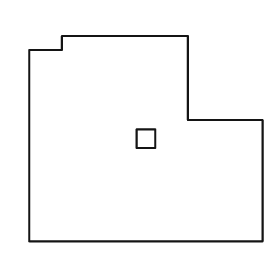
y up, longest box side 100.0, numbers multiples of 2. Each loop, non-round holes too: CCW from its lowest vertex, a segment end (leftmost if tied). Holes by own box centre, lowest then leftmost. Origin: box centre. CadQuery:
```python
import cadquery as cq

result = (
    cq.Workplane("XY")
    .moveTo(-50.0, -44.0)
    .lineTo(50.0, -44.0)
    .lineTo(50.0, 8.0)
    .lineTo(18.0, 8.0)
    .lineTo(18.0, 44.0)
    .lineTo(-36.0, 44.0)
    .lineTo(-36.0, 38.0)
    .lineTo(-50.0, 38.0)
    .close()
    .moveTo(-4.0, -4.0)
    .lineTo(4.0, -4.0)
    .lineTo(4.0, 4.0)
    .lineTo(-4.0, 4.0)
    .close()
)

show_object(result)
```